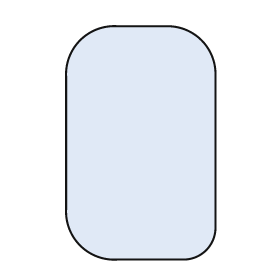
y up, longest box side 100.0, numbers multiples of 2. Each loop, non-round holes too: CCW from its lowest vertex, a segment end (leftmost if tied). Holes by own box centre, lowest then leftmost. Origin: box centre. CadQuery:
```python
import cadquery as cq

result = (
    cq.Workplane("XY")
    .moveTo(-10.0, -50.0)
    .lineTo(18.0, -50.0)
    .threePointArc((28.0, -46.0), (32.0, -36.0))
    .lineTo(32.0, 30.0)
    .threePointArc((26.0, 44.0), (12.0, 50.0))
    .lineTo(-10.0, 50.0)
    .threePointArc((-26.0, 44.0), (-32.0, 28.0))
    .lineTo(-32.0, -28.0)
    .threePointArc((-26.0, -44.0), (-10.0, -50.0))
    .close()
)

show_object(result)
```